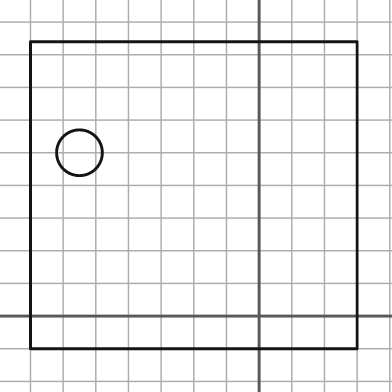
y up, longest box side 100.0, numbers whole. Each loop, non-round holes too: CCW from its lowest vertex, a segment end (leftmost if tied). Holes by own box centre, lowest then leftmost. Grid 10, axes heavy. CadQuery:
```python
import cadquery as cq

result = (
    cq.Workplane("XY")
    .moveTo(-70.0, -10.0)
    .lineTo(30.0, -10.0)
    .lineTo(30.0, 84.0)
    .lineTo(-70.0, 84.0)
    .close()
    .moveTo(-55.0, 50.0)
    .circle(7.0)
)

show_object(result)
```